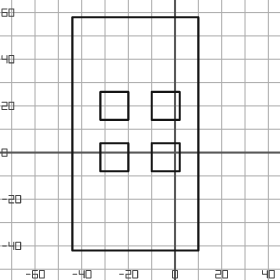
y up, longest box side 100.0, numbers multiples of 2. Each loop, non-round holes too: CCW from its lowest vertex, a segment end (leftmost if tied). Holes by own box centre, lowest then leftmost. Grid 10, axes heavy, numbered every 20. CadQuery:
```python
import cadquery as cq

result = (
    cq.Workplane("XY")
    .moveTo(-44.0, -42.0)
    .lineTo(10.0, -42.0)
    .lineTo(10.0, 58.0)
    .lineTo(-44.0, 58.0)
    .close()
    .moveTo(-32.0, -8.0)
    .lineTo(-20.0, -8.0)
    .lineTo(-20.0, 4.0)
    .lineTo(-32.0, 4.0)
    .close()
    .moveTo(-10.0, -8.0)
    .lineTo(2.0, -8.0)
    .lineTo(2.0, 4.0)
    .lineTo(-10.0, 4.0)
    .close()
    .moveTo(-32.0, 14.0)
    .lineTo(-20.0, 14.0)
    .lineTo(-20.0, 26.0)
    .lineTo(-32.0, 26.0)
    .close()
    .moveTo(-10.0, 14.0)
    .lineTo(2.0, 14.0)
    .lineTo(2.0, 26.0)
    .lineTo(-10.0, 26.0)
    .close()
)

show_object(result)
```